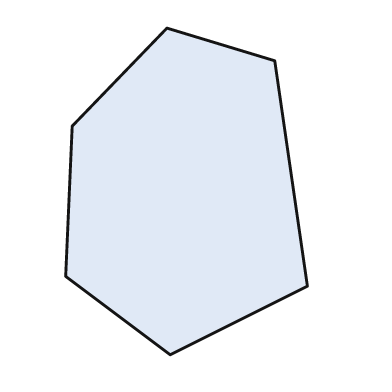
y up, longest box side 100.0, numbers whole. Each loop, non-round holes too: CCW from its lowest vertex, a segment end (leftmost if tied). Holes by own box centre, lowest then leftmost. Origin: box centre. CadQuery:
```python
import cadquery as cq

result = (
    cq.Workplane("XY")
    .moveTo(-5.0, -50.0)
    .lineTo(37.0, -29.0)
    .lineTo(27.0, 40.0)
    .lineTo(-6.0, 50.0)
    .lineTo(-35.0, 20.0)
    .lineTo(-37.0, -26.0)
    .close()
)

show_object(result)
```